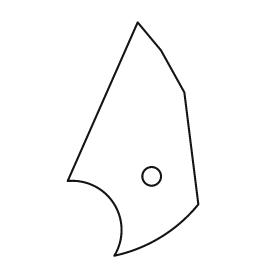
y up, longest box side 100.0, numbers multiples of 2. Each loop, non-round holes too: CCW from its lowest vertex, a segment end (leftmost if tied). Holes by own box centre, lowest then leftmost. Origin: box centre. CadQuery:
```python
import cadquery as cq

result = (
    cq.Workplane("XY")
    .moveTo(-8.0, -50.0)
    .threePointArc((12.0, -42.0), (28.0, -28.0))
    .lineTo(22.0, 20.0)
    .lineTo(12.0, 38.0)
    .lineTo(2.0, 50.0)
    .lineTo(-28.0, -18.0)
    .threePointArc((-8.0, -28.0), (-8.0, -50.0))
    .close()
    .moveTo(8.0, -16.0)
    .circle(4.0)
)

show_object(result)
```